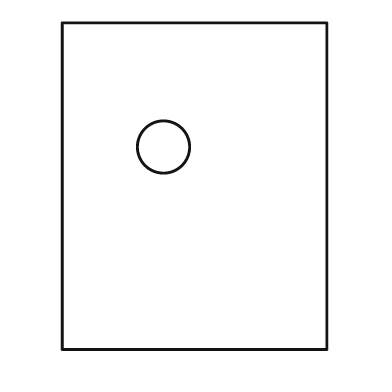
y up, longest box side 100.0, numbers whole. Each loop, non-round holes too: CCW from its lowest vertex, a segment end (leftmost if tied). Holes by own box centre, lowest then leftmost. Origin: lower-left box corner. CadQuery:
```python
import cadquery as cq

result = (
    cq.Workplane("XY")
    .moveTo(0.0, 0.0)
    .lineTo(81.0, 0.0)
    .lineTo(81.0, 100.0)
    .lineTo(0.0, 100.0)
    .close()
    .moveTo(31.0, 62.0)
    .circle(8.0)
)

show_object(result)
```